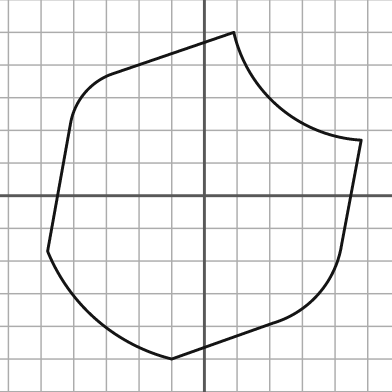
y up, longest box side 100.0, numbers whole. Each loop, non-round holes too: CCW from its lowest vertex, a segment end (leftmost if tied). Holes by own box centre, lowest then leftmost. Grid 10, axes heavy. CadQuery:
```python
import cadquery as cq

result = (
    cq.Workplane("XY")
    .moveTo(-10.0, -50.0)
    .lineTo(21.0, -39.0)
    .threePointArc((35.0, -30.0), (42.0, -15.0))
    .lineTo(48.0, 17.0)
    .threePointArc((23.0, 27.0), (9.0, 50.0))
    .lineTo(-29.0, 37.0)
    .threePointArc((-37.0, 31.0), (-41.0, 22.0))
    .lineTo(-48.0, -17.0)
    .threePointArc((-33.0, -38.0), (-10.0, -50.0))
    .close()
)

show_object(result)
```